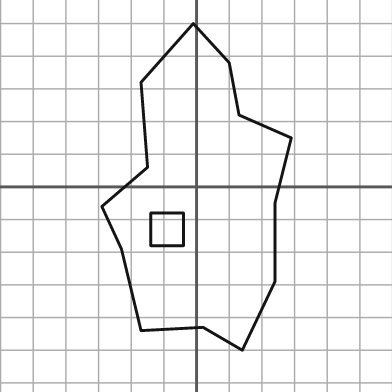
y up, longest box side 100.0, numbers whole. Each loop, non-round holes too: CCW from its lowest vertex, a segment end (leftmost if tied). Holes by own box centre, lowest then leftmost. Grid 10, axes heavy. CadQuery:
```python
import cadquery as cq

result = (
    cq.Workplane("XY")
    .moveTo(14.0, -50.0)
    .lineTo(24.0, -29.0)
    .lineTo(24.0, -5.0)
    .lineTo(29.0, 15.0)
    .lineTo(13.0, 22.0)
    .lineTo(10.0, 38.0)
    .lineTo(-1.0, 50.0)
    .lineTo(-17.0, 32.0)
    .lineTo(-15.0, 6.0)
    .lineTo(-29.0, -6.0)
    .lineTo(-23.0, -19.0)
    .lineTo(-17.0, -44.0)
    .lineTo(2.0, -43.0)
    .close()
    .moveTo(-14.0, -18.0)
    .lineTo(-4.0, -18.0)
    .lineTo(-4.0, -8.0)
    .lineTo(-14.0, -8.0)
    .close()
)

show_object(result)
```